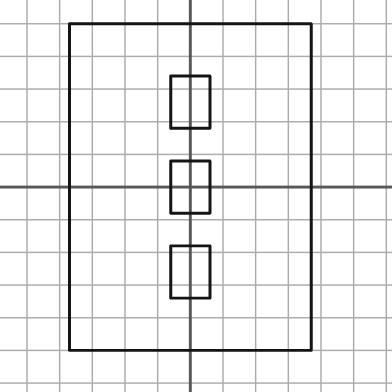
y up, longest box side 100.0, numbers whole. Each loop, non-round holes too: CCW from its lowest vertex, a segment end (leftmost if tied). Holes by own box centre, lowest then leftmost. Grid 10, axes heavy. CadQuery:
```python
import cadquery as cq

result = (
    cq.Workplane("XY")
    .moveTo(-37.0, -50.0)
    .lineTo(37.0, -50.0)
    .lineTo(37.0, 50.0)
    .lineTo(-37.0, 50.0)
    .close()
    .moveTo(-6.0, -34.0)
    .lineTo(6.0, -34.0)
    .lineTo(6.0, -18.0)
    .lineTo(-6.0, -18.0)
    .close()
    .moveTo(-6.0, -8.0)
    .lineTo(6.0, -8.0)
    .lineTo(6.0, 8.0)
    .lineTo(-6.0, 8.0)
    .close()
    .moveTo(-6.0, 18.0)
    .lineTo(6.0, 18.0)
    .lineTo(6.0, 34.0)
    .lineTo(-6.0, 34.0)
    .close()
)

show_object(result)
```